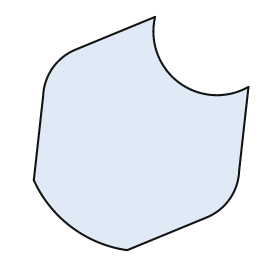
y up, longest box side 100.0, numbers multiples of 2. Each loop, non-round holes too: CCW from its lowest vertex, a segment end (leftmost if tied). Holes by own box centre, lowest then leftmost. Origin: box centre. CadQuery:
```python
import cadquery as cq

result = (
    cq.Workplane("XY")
    .moveTo(-6.0, -50.0)
    .lineTo(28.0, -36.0)
    .threePointArc((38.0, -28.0), (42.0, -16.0))
    .lineTo(46.0, 20.0)
    .threePointArc((16.0, 22.0), (6.0, 50.0))
    .lineTo(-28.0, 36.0)
    .threePointArc((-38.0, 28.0), (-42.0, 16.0))
    .lineTo(-46.0, -20.0)
    .threePointArc((-30.0, -40.0), (-6.0, -50.0))
    .close()
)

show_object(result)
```